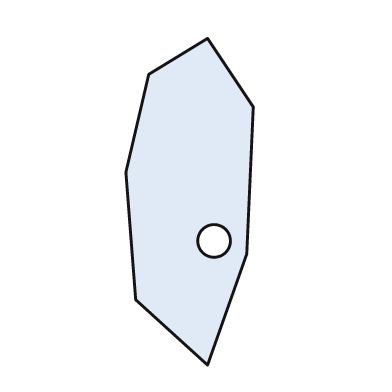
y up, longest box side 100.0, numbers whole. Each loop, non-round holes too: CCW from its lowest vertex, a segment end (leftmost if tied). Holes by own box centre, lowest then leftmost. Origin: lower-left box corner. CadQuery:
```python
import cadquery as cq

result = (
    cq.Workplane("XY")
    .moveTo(25.0, 0.0)
    .lineTo(37.0, 34.0)
    .lineTo(39.0, 79.0)
    .lineTo(25.0, 100.0)
    .lineTo(7.0, 89.0)
    .lineTo(0.0, 59.0)
    .lineTo(3.0, 20.0)
    .close()
    .moveTo(27.0, 38.0)
    .circle(5.0)
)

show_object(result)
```